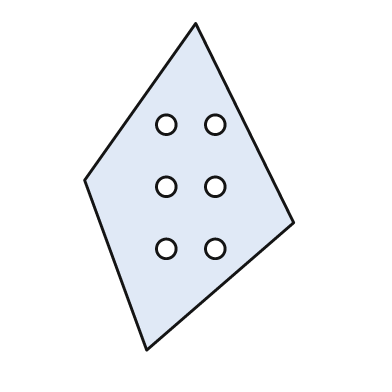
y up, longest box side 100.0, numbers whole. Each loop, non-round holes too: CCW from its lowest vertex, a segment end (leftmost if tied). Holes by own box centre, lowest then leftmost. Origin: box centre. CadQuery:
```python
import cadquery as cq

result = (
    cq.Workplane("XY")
    .moveTo(-13.0, -50.0)
    .lineTo(32.0, -11.0)
    .lineTo(2.0, 50.0)
    .lineTo(-32.0, 2.0)
    .close()
    .moveTo(-7.0, -19.0)
    .circle(3.0)
    .moveTo(8.0, -19.0)
    .circle(3.0)
    .moveTo(-7.0, 0.0)
    .circle(3.0)
    .moveTo(8.0, 0.0)
    .circle(3.0)
    .moveTo(-7.0, 19.0)
    .circle(3.0)
    .moveTo(8.0, 19.0)
    .circle(3.0)
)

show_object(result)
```